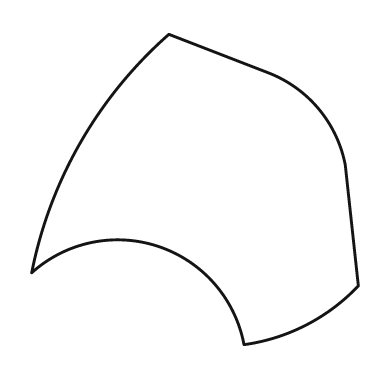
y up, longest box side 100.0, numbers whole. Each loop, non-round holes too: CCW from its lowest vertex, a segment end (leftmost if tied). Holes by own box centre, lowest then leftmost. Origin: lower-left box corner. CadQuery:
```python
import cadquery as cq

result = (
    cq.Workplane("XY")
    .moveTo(65.0, 0.0)
    .threePointArc((84.0, 6.0), (100.0, 18.0))
    .lineTo(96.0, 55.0)
    .threePointArc((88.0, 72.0), (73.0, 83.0))
    .lineTo(42.0, 95.0)
    .threePointArc((15.0, 62.0), (0.0, 22.0))
    .threePointArc((39.0, 30.0), (65.0, 0.0))
    .close()
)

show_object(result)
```